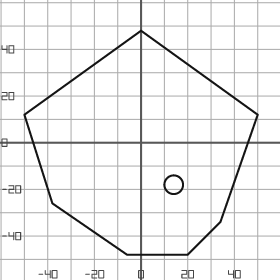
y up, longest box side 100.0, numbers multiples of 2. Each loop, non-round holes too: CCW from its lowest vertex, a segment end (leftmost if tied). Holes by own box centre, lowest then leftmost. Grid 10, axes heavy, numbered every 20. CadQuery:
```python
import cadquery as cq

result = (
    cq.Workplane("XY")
    .moveTo(-6.0, -48.0)
    .lineTo(20.0, -48.0)
    .lineTo(34.0, -34.0)
    .lineTo(50.0, 12.0)
    .lineTo(0.0, 48.0)
    .lineTo(-50.0, 12.0)
    .lineTo(-38.0, -26.0)
    .close()
    .moveTo(14.0, -18.0)
    .circle(4.0)
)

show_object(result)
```